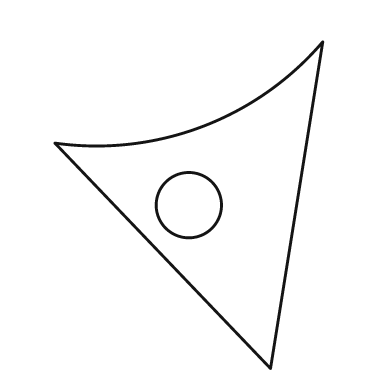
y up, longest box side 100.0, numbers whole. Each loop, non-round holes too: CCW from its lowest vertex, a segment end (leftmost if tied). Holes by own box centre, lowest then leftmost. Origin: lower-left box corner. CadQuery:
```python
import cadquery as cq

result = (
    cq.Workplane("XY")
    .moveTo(66.0, 0.0)
    .lineTo(82.0, 100.0)
    .threePointArc((45.0, 74.0), (0.0, 69.0))
    .close()
    .moveTo(41.0, 50.0)
    .circle(10.0)
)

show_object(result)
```